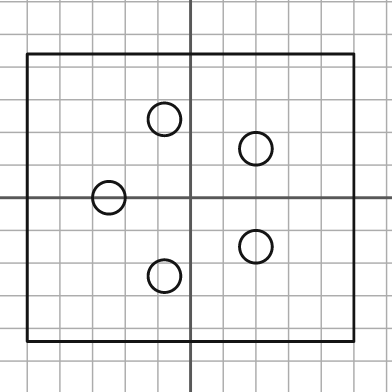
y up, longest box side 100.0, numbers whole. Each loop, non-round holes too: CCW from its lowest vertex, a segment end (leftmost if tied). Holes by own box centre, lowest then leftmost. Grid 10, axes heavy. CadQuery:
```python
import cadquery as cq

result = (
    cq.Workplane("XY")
    .moveTo(-50.0, -44.0)
    .lineTo(50.0, -44.0)
    .lineTo(50.0, 44.0)
    .lineTo(-50.0, 44.0)
    .close()
    .moveTo(-8.0, -24.0)
    .circle(5.0)
    .moveTo(20.0, -15.0)
    .circle(5.0)
    .moveTo(-25.0, 0.0)
    .circle(5.0)
    .moveTo(20.0, 15.0)
    .circle(5.0)
    .moveTo(-8.0, 24.0)
    .circle(5.0)
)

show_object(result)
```